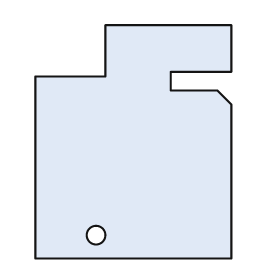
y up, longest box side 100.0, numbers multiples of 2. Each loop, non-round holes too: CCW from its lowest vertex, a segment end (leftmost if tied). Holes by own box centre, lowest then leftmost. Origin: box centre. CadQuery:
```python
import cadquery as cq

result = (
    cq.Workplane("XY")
    .moveTo(-42.0, -50.0)
    .lineTo(42.0, -50.0)
    .lineTo(42.0, 16.0)
    .lineTo(36.0, 22.0)
    .lineTo(16.0, 22.0)
    .lineTo(16.0, 30.0)
    .lineTo(42.0, 30.0)
    .lineTo(42.0, 50.0)
    .lineTo(-12.0, 50.0)
    .lineTo(-12.0, 28.0)
    .lineTo(-42.0, 28.0)
    .close()
    .moveTo(-16.0, -40.0)
    .circle(4.0)
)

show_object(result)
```